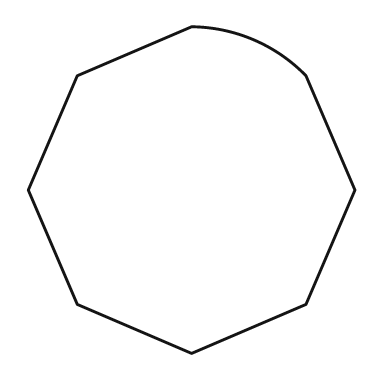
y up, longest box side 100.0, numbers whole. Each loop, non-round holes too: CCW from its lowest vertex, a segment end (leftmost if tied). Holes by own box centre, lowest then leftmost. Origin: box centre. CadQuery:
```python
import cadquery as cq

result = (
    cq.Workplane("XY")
    .moveTo(0.0, -50.0)
    .lineTo(35.0, -35.0)
    .lineTo(50.0, 0.0)
    .lineTo(35.0, 35.0)
    .threePointArc((19.0, 46.0), (0.0, 50.0))
    .lineTo(-35.0, 35.0)
    .lineTo(-50.0, 0.0)
    .lineTo(-35.0, -35.0)
    .close()
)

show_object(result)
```